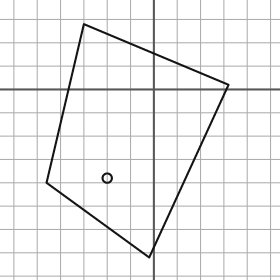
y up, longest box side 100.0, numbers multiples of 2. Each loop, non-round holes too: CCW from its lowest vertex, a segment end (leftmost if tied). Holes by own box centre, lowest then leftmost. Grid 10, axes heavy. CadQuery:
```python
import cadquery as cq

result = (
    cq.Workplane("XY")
    .moveTo(-2.0, -72.0)
    .lineTo(32.0, 2.0)
    .lineTo(-30.0, 28.0)
    .lineTo(-46.0, -40.0)
    .close()
    .moveTo(-20.0, -38.0)
    .circle(2.0)
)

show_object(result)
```